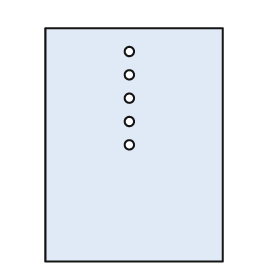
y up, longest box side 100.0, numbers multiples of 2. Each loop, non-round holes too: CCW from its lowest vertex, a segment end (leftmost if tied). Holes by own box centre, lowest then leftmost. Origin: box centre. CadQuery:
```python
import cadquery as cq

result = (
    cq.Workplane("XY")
    .moveTo(-38.0, -50.0)
    .lineTo(38.0, -50.0)
    .lineTo(38.0, 50.0)
    .lineTo(-38.0, 50.0)
    .close()
    .moveTo(-2.0, 0.0)
    .circle(2.0)
    .moveTo(-2.0, 10.0)
    .circle(2.0)
    .moveTo(-2.0, 20.0)
    .circle(2.0)
    .moveTo(-2.0, 30.0)
    .circle(2.0)
    .moveTo(-2.0, 40.0)
    .circle(2.0)
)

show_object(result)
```